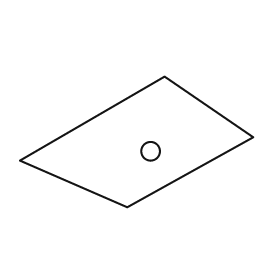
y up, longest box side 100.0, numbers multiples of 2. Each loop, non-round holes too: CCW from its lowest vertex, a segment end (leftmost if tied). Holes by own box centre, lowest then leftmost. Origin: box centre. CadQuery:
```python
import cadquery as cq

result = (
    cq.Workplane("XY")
    .moveTo(-4.0, -28.0)
    .lineTo(50.0, 2.0)
    .lineTo(12.0, 28.0)
    .lineTo(-50.0, -8.0)
    .close()
    .moveTo(6.0, -4.0)
    .circle(4.0)
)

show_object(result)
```